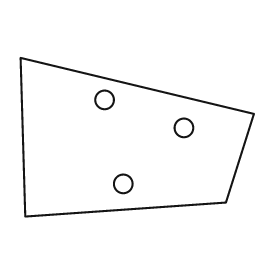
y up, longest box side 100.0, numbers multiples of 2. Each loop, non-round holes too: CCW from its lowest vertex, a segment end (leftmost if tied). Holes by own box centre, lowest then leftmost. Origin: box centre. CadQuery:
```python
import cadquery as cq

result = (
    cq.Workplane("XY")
    .moveTo(-48.0, -34.0)
    .lineTo(38.0, -28.0)
    .lineTo(50.0, 10.0)
    .lineTo(-50.0, 34.0)
    .close()
    .moveTo(-6.0, -20.0)
    .circle(4.0)
    .moveTo(20.0, 4.0)
    .circle(4.0)
    .moveTo(-14.0, 16.0)
    .circle(4.0)
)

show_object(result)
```